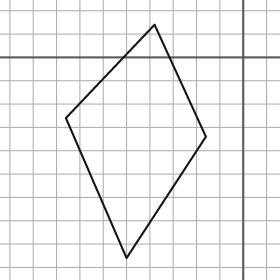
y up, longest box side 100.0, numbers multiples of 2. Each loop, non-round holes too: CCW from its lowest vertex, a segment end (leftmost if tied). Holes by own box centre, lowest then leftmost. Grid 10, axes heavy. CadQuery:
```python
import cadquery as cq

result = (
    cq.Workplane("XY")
    .moveTo(-50.0, -86.0)
    .lineTo(-16.0, -34.0)
    .lineTo(-38.0, 14.0)
    .lineTo(-76.0, -26.0)
    .close()
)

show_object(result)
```